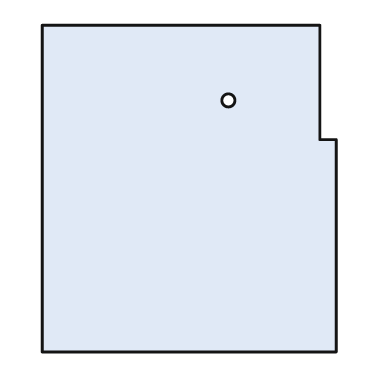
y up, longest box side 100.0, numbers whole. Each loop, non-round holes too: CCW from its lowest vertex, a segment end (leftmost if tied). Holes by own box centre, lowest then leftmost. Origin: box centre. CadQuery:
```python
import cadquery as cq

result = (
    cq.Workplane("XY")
    .moveTo(-45.0, -50.0)
    .lineTo(45.0, -50.0)
    .lineTo(45.0, 15.0)
    .lineTo(40.0, 15.0)
    .lineTo(40.0, 50.0)
    .lineTo(-45.0, 50.0)
    .close()
    .moveTo(12.0, 27.0)
    .circle(2.0)
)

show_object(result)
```